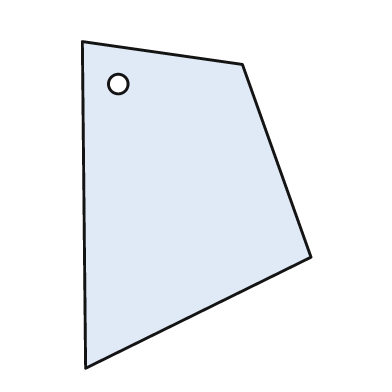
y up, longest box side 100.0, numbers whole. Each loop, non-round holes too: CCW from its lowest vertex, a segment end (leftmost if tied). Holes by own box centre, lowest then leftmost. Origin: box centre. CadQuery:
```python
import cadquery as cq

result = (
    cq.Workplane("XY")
    .moveTo(-34.0, -50.0)
    .lineTo(35.0, -16.0)
    .lineTo(14.0, 43.0)
    .lineTo(-35.0, 50.0)
    .close()
    .moveTo(-24.0, 37.0)
    .circle(3.0)
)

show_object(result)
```